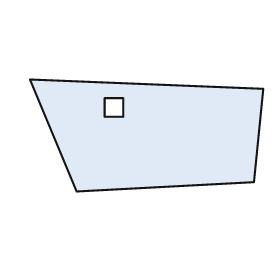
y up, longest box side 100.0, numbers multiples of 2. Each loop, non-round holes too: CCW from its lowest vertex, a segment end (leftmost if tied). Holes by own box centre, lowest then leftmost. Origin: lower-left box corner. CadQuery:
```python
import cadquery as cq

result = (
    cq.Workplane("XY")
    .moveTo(20.0, 0.0)
    .lineTo(96.0, 4.0)
    .lineTo(100.0, 44.0)
    .lineTo(0.0, 48.0)
    .close()
    .moveTo(32.0, 32.0)
    .lineTo(40.0, 32.0)
    .lineTo(40.0, 40.0)
    .lineTo(32.0, 40.0)
    .close()
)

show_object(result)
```